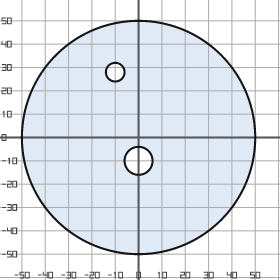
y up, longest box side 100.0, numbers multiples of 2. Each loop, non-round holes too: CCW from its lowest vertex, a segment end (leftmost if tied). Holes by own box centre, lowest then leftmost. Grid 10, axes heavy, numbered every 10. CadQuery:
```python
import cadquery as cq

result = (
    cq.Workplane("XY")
    .moveTo(0.0, 0.0)
    .circle(50.0)
    .moveTo(0.0, -10.0)
    .circle(6.0)
    .moveTo(-10.0, 28.0)
    .circle(4.0)
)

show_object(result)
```